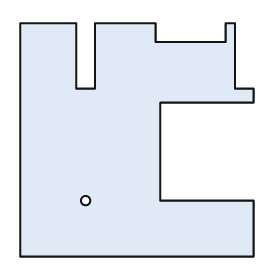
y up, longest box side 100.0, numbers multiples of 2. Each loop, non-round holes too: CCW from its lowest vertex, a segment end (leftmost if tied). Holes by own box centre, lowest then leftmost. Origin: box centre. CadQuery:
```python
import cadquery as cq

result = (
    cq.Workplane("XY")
    .moveTo(-50.0, -50.0)
    .lineTo(50.0, -50.0)
    .lineTo(50.0, -26.0)
    .lineTo(10.0, -26.0)
    .lineTo(10.0, 16.0)
    .lineTo(50.0, 16.0)
    .lineTo(50.0, 22.0)
    .lineTo(42.0, 22.0)
    .lineTo(42.0, 50.0)
    .lineTo(38.0, 50.0)
    .lineTo(38.0, 42.0)
    .lineTo(8.0, 42.0)
    .lineTo(8.0, 50.0)
    .lineTo(-18.0, 50.0)
    .lineTo(-18.0, 22.0)
    .lineTo(-26.0, 22.0)
    .lineTo(-26.0, 50.0)
    .lineTo(-50.0, 50.0)
    .close()
    .moveTo(-22.0, -26.0)
    .circle(2.0)
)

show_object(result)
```